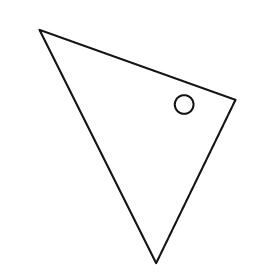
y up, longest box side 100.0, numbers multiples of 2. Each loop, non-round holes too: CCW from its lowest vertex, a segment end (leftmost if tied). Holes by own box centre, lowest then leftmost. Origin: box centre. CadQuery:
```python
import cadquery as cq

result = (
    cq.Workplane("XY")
    .moveTo(8.0, -50.0)
    .lineTo(42.0, 20.0)
    .lineTo(-42.0, 50.0)
    .close()
    .moveTo(20.0, 18.0)
    .circle(4.0)
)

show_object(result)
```